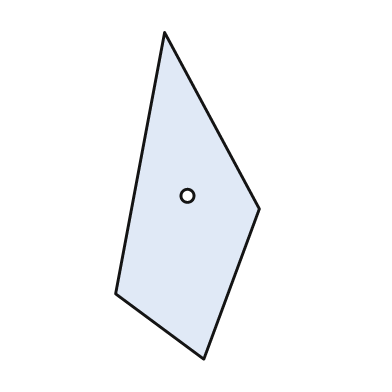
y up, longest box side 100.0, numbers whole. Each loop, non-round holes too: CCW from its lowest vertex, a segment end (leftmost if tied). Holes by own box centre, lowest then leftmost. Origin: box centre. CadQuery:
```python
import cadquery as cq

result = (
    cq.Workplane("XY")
    .moveTo(5.0, -50.0)
    .lineTo(22.0, -4.0)
    .lineTo(-7.0, 50.0)
    .lineTo(-22.0, -30.0)
    .close()
    .moveTo(0.0, 0.0)
    .circle(2.0)
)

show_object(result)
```